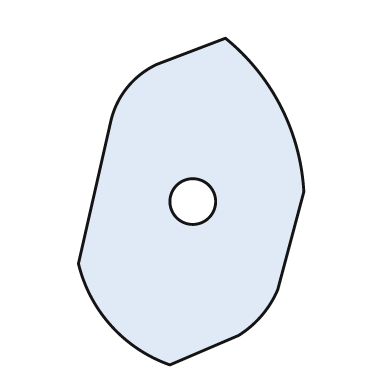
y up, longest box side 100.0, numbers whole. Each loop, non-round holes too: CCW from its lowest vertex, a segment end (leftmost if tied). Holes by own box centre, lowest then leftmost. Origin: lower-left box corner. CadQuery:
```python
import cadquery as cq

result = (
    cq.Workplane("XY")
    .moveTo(28.0, 0.0)
    .lineTo(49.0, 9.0)
    .threePointArc((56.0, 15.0), (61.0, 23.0))
    .lineTo(69.0, 53.0)
    .threePointArc((62.0, 79.0), (45.0, 100.0))
    .lineTo(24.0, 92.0)
    .threePointArc((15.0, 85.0), (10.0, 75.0))
    .lineTo(0.0, 31.0)
    .threePointArc((10.0, 12.0), (28.0, 0.0))
    .close()
    .moveTo(35.0, 50.0)
    .circle(7.0)
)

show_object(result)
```